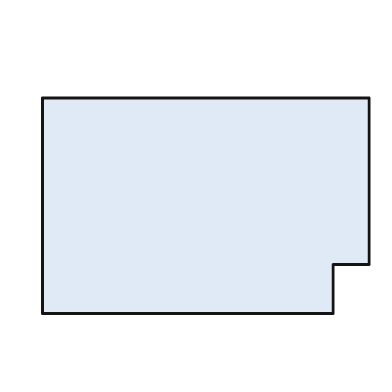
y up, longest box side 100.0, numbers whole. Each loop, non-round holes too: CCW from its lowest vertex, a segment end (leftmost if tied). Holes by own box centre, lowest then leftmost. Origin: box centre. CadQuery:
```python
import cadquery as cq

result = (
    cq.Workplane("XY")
    .moveTo(-50.0, -33.0)
    .lineTo(39.0, -33.0)
    .lineTo(39.0, -18.0)
    .lineTo(50.0, -18.0)
    .lineTo(50.0, 33.0)
    .lineTo(-50.0, 33.0)
    .close()
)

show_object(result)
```